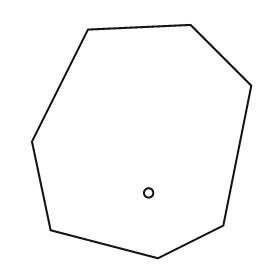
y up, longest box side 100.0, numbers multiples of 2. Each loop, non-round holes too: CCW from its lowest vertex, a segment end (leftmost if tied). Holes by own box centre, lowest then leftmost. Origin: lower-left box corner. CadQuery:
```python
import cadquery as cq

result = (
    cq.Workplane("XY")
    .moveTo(54.0, 0.0)
    .lineTo(82.0, 14.0)
    .lineTo(94.0, 74.0)
    .lineTo(68.0, 100.0)
    .lineTo(24.0, 98.0)
    .lineTo(0.0, 50.0)
    .lineTo(8.0, 12.0)
    .close()
    .moveTo(50.0, 28.0)
    .circle(2.0)
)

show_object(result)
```